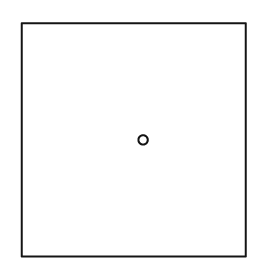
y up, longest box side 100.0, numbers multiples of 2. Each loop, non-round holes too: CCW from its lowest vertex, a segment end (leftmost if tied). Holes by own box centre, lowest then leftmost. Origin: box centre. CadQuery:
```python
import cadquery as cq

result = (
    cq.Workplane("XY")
    .moveTo(-48.0, -50.0)
    .lineTo(48.0, -50.0)
    .lineTo(48.0, 50.0)
    .lineTo(-48.0, 50.0)
    .close()
    .moveTo(4.0, 0.0)
    .circle(2.0)
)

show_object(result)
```